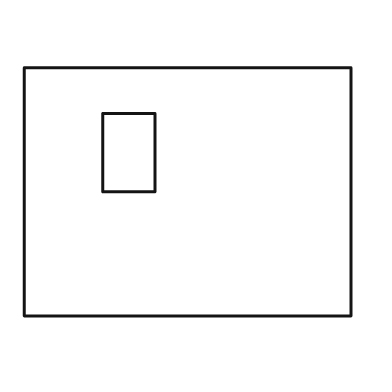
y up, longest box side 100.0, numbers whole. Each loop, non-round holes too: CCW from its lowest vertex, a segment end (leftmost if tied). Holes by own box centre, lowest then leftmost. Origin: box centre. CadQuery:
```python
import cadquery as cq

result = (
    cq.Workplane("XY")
    .moveTo(-50.0, -38.0)
    .lineTo(50.0, -38.0)
    .lineTo(50.0, 38.0)
    .lineTo(-50.0, 38.0)
    .close()
    .moveTo(-26.0, 0.0)
    .lineTo(-10.0, 0.0)
    .lineTo(-10.0, 24.0)
    .lineTo(-26.0, 24.0)
    .close()
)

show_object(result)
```